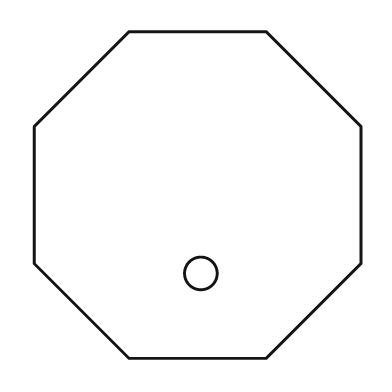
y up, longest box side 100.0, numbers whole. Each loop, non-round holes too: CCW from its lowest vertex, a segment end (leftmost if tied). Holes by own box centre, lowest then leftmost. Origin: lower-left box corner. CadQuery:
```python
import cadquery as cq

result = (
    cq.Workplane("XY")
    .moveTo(29.0, 0.0)
    .lineTo(71.0, 0.0)
    .lineTo(100.0, 29.0)
    .lineTo(100.0, 71.0)
    .lineTo(71.0, 100.0)
    .lineTo(29.0, 100.0)
    .lineTo(0.0, 71.0)
    .lineTo(0.0, 29.0)
    .close()
    .moveTo(51.0, 26.0)
    .circle(5.0)
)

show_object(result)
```